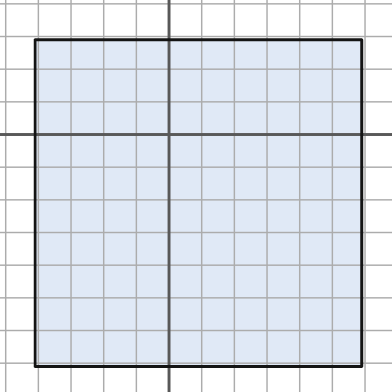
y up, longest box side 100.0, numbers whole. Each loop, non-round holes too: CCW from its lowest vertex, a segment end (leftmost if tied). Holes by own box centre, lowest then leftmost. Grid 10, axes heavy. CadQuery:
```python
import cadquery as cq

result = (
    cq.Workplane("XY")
    .moveTo(-41.0, -71.0)
    .lineTo(59.0, -71.0)
    .lineTo(59.0, 29.0)
    .lineTo(-41.0, 29.0)
    .close()
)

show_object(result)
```